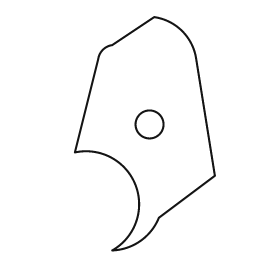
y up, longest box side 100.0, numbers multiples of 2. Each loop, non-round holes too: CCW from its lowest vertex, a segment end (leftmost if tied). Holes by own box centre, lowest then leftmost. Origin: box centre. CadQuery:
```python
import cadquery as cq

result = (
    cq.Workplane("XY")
    .moveTo(-14.0, -50.0)
    .threePointArc((-2.0, -46.0), (6.0, -36.0))
    .lineTo(30.0, -18.0)
    .lineTo(22.0, 32.0)
    .threePointArc((16.0, 44.0), (4.0, 50.0))
    .lineTo(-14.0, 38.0)
    .threePointArc((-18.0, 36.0), (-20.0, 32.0))
    .lineTo(-30.0, -8.0)
    .threePointArc((-4.0, -22.0), (-14.0, -50.0))
    .close()
    .moveTo(2.0, 4.0)
    .circle(6.0)
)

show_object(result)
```